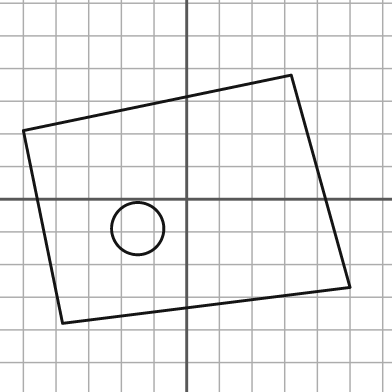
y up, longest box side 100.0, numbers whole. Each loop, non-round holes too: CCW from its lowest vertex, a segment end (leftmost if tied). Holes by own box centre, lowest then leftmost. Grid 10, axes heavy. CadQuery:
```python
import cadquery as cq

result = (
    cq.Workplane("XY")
    .moveTo(-38.0, -38.0)
    .lineTo(50.0, -27.0)
    .lineTo(32.0, 38.0)
    .lineTo(-50.0, 21.0)
    .close()
    .moveTo(-15.0, -9.0)
    .circle(8.0)
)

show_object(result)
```